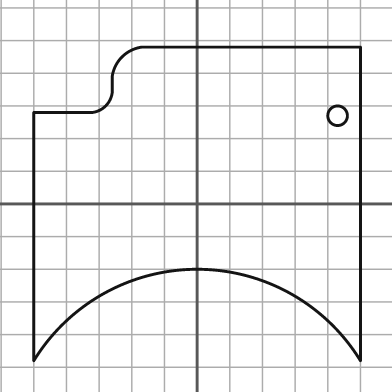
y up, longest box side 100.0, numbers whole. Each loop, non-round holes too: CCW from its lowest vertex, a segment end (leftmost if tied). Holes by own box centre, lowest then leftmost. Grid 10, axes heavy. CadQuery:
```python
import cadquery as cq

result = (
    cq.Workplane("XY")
    .moveTo(-50.0, -48.0)
    .threePointArc((0.0, -20.0), (50.0, -48.0))
    .lineTo(50.0, 48.0)
    .lineTo(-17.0, 48.0)
    .threePointArc((-23.0, 45.0), (-26.0, 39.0))
    .lineTo(-26.0, 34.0)
    .threePointArc((-28.0, 30.0), (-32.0, 28.0))
    .lineTo(-50.0, 28.0)
    .close()
    .moveTo(43.0, 27.0)
    .circle(3.0)
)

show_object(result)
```